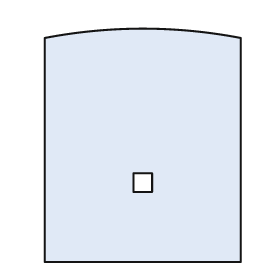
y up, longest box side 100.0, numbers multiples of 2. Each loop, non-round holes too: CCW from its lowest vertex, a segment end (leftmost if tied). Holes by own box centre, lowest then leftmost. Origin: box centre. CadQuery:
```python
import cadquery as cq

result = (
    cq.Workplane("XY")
    .moveTo(-42.0, -50.0)
    .lineTo(42.0, -50.0)
    .lineTo(42.0, 46.0)
    .threePointArc((0.0, 50.0), (-42.0, 46.0))
    .close()
    .moveTo(-4.0, -20.0)
    .lineTo(4.0, -20.0)
    .lineTo(4.0, -12.0)
    .lineTo(-4.0, -12.0)
    .close()
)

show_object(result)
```